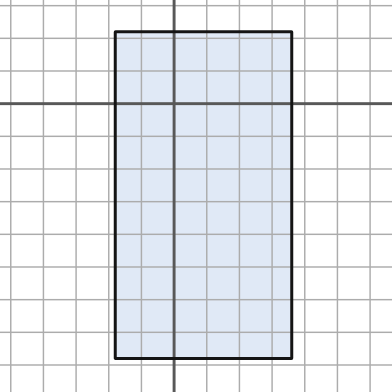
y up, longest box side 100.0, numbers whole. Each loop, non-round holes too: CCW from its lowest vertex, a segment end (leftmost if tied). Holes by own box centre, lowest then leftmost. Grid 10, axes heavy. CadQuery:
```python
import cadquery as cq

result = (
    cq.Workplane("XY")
    .moveTo(-18.0, -78.0)
    .lineTo(36.0, -78.0)
    .lineTo(36.0, 22.0)
    .lineTo(-18.0, 22.0)
    .close()
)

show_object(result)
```